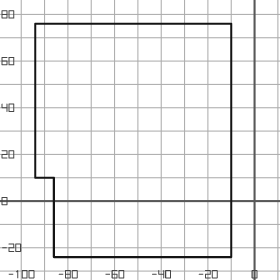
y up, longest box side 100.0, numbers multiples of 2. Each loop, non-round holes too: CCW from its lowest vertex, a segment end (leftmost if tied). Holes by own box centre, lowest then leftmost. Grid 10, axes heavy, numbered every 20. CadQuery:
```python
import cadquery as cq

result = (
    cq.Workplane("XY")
    .moveTo(-86.0, -24.0)
    .lineTo(-10.0, -24.0)
    .lineTo(-10.0, 76.0)
    .lineTo(-94.0, 76.0)
    .lineTo(-94.0, 10.0)
    .lineTo(-86.0, 10.0)
    .close()
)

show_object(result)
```